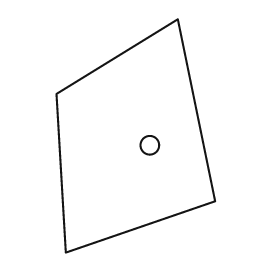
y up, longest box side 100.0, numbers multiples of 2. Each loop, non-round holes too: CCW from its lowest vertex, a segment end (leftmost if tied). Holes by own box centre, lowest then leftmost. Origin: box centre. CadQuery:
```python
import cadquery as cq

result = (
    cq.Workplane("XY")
    .moveTo(-30.0, -50.0)
    .lineTo(34.0, -28.0)
    .lineTo(18.0, 50.0)
    .lineTo(-34.0, 18.0)
    .close()
    .moveTo(6.0, -4.0)
    .circle(4.0)
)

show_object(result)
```